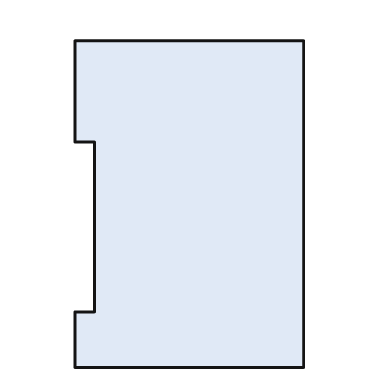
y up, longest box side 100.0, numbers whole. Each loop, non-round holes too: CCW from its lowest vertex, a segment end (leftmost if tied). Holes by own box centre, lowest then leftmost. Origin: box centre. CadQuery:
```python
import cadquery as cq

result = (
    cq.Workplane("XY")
    .moveTo(-35.0, -50.0)
    .lineTo(35.0, -50.0)
    .lineTo(35.0, 50.0)
    .lineTo(-35.0, 50.0)
    .lineTo(-35.0, 19.0)
    .lineTo(-29.0, 19.0)
    .lineTo(-29.0, -33.0)
    .lineTo(-35.0, -33.0)
    .close()
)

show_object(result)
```